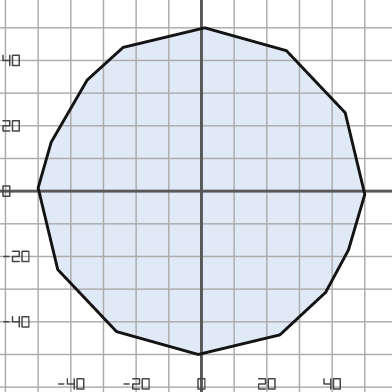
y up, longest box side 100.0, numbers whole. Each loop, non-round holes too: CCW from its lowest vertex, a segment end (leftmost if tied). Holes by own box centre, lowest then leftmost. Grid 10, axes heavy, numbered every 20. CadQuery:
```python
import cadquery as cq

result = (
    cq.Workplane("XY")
    .moveTo(-1.0, -50.0)
    .lineTo(24.0, -44.0)
    .lineTo(38.0, -31.0)
    .lineTo(45.0, -18.0)
    .lineTo(50.0, -1.0)
    .lineTo(44.0, 24.0)
    .lineTo(26.0, 43.0)
    .lineTo(1.0, 50.0)
    .lineTo(-24.0, 44.0)
    .lineTo(-35.0, 34.0)
    .lineTo(-46.0, 15.0)
    .lineTo(-50.0, 1.0)
    .lineTo(-44.0, -24.0)
    .lineTo(-26.0, -43.0)
    .close()
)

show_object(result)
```